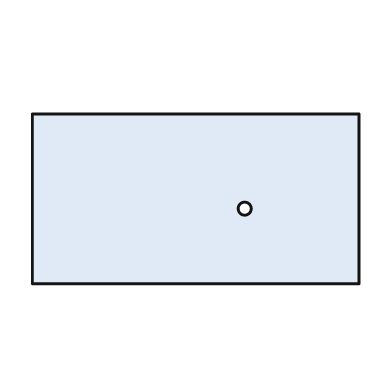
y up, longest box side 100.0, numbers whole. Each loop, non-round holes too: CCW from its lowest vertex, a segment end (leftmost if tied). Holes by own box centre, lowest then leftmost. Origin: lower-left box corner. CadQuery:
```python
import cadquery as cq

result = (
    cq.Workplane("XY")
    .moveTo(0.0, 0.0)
    .lineTo(100.0, 0.0)
    .lineTo(100.0, 52.0)
    .lineTo(0.0, 52.0)
    .close()
    .moveTo(65.0, 23.0)
    .circle(2.0)
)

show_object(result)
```